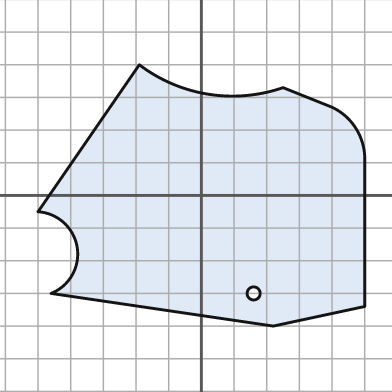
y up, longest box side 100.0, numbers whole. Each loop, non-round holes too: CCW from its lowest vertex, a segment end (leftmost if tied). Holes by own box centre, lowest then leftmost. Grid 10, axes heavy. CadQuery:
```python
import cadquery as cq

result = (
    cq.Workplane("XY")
    .moveTo(22.0, -40.0)
    .lineTo(50.0, -34.0)
    .lineTo(50.0, 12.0)
    .threePointArc((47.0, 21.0), (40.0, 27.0))
    .lineTo(25.0, 33.0)
    .threePointArc((2.0, 31.0), (-19.0, 40.0))
    .lineTo(-50.0, -5.0)
    .threePointArc((-38.0, -16.0), (-46.0, -30.0))
    .close()
    .moveTo(16.0, -30.0)
    .circle(2.0)
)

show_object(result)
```